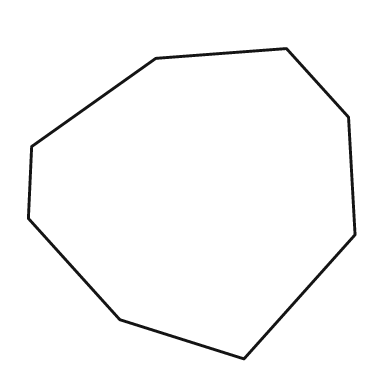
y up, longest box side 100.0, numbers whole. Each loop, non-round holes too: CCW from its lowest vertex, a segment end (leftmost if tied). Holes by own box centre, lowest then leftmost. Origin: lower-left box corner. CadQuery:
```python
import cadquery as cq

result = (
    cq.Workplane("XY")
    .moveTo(66.0, 0.0)
    .lineTo(100.0, 38.0)
    .lineTo(98.0, 74.0)
    .lineTo(79.0, 95.0)
    .lineTo(39.0, 92.0)
    .lineTo(1.0, 65.0)
    .lineTo(0.0, 43.0)
    .lineTo(28.0, 12.0)
    .close()
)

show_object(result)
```